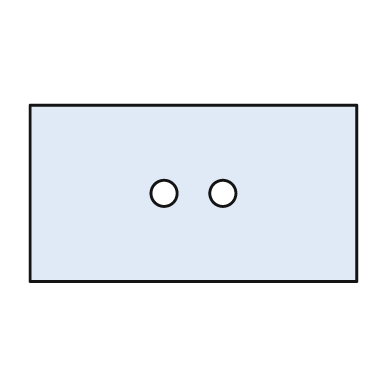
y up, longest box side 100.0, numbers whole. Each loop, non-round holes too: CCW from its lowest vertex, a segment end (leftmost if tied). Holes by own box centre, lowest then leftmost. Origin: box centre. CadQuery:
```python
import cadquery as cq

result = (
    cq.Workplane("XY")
    .moveTo(-50.0, -27.0)
    .lineTo(50.0, -27.0)
    .lineTo(50.0, 27.0)
    .lineTo(-50.0, 27.0)
    .close()
    .moveTo(-9.0, 0.0)
    .circle(4.0)
    .moveTo(9.0, 0.0)
    .circle(4.0)
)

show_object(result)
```